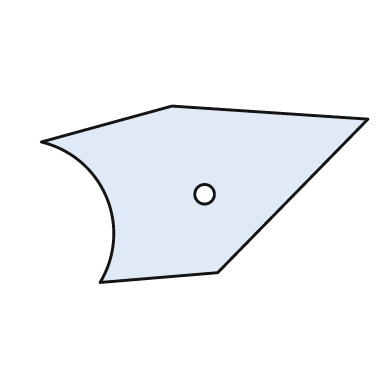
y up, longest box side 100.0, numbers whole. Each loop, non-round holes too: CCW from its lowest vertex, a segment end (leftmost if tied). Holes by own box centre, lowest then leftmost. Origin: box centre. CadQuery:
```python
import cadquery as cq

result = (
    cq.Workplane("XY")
    .moveTo(-32.0, -27.0)
    .lineTo(4.0, -24.0)
    .lineTo(50.0, 23.0)
    .lineTo(-10.0, 27.0)
    .lineTo(-50.0, 16.0)
    .threePointArc((-30.0, -1.0), (-32.0, -27.0))
    .close()
    .moveTo(0.0, 0.0)
    .circle(3.0)
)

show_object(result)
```